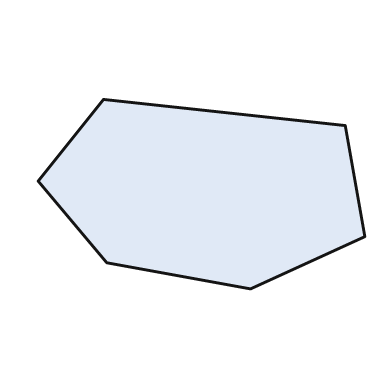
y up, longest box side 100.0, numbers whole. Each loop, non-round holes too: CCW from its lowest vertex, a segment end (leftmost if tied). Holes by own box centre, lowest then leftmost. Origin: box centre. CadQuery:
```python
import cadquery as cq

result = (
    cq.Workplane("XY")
    .moveTo(15.0, -29.0)
    .lineTo(50.0, -13.0)
    .lineTo(44.0, 21.0)
    .lineTo(-30.0, 29.0)
    .lineTo(-50.0, 4.0)
    .lineTo(-29.0, -21.0)
    .close()
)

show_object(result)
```